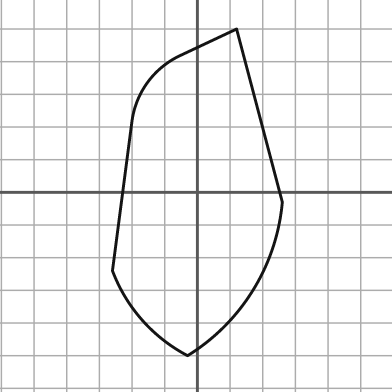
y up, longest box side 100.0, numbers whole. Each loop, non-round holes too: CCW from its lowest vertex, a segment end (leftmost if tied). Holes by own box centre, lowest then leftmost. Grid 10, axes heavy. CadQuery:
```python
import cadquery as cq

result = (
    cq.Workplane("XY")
    .moveTo(-3.0, -50.0)
    .threePointArc((17.0, -30.0), (26.0, -3.0))
    .lineTo(12.0, 50.0)
    .lineTo(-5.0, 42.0)
    .threePointArc((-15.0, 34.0), (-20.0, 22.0))
    .lineTo(-26.0, -24.0)
    .threePointArc((-17.0, -39.0), (-3.0, -50.0))
    .close()
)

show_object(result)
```